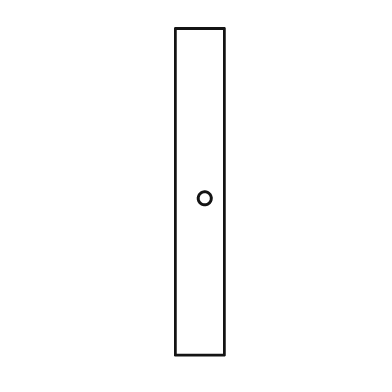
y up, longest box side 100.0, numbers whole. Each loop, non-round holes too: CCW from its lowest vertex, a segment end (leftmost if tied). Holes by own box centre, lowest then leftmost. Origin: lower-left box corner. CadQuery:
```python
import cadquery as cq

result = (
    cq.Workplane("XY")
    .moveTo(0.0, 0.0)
    .lineTo(15.0, 0.0)
    .lineTo(15.0, 100.0)
    .lineTo(0.0, 100.0)
    .close()
    .moveTo(9.0, 48.0)
    .circle(2.0)
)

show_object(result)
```